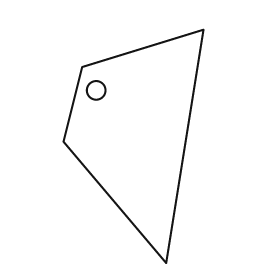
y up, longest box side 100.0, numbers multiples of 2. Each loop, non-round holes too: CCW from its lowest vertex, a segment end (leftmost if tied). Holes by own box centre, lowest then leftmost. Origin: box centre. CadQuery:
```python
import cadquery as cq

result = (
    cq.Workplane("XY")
    .moveTo(14.0, -50.0)
    .lineTo(30.0, 50.0)
    .lineTo(-22.0, 34.0)
    .lineTo(-30.0, 2.0)
    .close()
    .moveTo(-16.0, 24.0)
    .circle(4.0)
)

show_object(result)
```